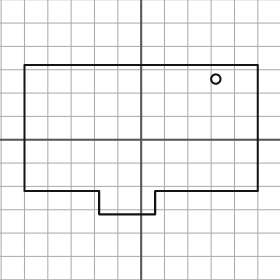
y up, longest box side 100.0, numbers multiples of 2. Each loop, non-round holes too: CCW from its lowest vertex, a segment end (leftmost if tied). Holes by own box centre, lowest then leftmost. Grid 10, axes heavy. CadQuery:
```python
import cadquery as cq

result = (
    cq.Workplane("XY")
    .moveTo(-18.0, -32.0)
    .lineTo(6.0, -32.0)
    .lineTo(6.0, -22.0)
    .lineTo(50.0, -22.0)
    .lineTo(50.0, 32.0)
    .lineTo(-50.0, 32.0)
    .lineTo(-50.0, -22.0)
    .lineTo(-18.0, -22.0)
    .close()
    .moveTo(32.0, 26.0)
    .circle(2.0)
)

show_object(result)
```